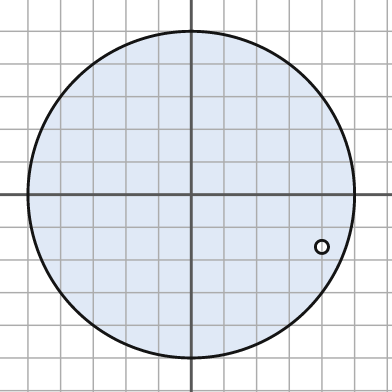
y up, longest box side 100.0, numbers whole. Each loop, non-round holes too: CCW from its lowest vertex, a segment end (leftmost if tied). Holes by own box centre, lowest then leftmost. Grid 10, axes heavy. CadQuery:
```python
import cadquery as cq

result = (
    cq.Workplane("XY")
    .moveTo(0.0, 0.0)
    .circle(50.0)
    .moveTo(40.0, -16.0)
    .circle(2.0)
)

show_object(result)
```